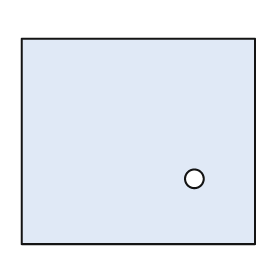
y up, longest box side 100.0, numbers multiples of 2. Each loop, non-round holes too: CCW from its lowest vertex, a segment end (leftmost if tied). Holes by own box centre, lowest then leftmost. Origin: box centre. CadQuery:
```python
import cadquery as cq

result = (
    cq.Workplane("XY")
    .moveTo(-50.0, -44.0)
    .lineTo(50.0, -44.0)
    .lineTo(50.0, 44.0)
    .lineTo(-50.0, 44.0)
    .close()
    .moveTo(24.0, -16.0)
    .circle(4.0)
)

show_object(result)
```